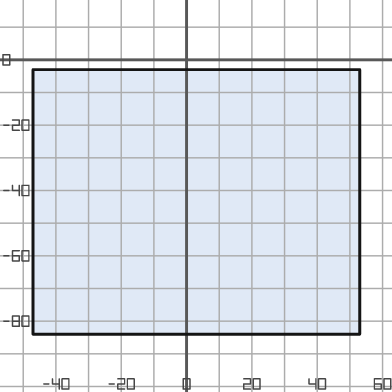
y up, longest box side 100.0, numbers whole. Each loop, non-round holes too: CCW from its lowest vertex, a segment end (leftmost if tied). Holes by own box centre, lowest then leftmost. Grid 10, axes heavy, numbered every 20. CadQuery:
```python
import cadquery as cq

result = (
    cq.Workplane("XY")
    .moveTo(-47.0, -84.0)
    .lineTo(53.0, -84.0)
    .lineTo(53.0, -3.0)
    .lineTo(-47.0, -3.0)
    .close()
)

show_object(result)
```